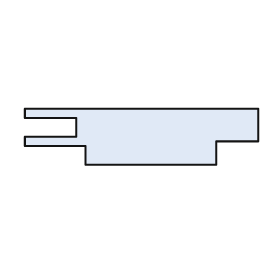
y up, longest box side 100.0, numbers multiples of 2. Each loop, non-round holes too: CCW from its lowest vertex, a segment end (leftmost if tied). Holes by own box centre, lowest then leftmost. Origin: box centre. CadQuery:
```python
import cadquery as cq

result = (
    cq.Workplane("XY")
    .moveTo(-24.0, -12.0)
    .lineTo(32.0, -12.0)
    .lineTo(32.0, -2.0)
    .lineTo(50.0, -2.0)
    .lineTo(50.0, 12.0)
    .lineTo(-50.0, 12.0)
    .lineTo(-50.0, 8.0)
    .lineTo(-28.0, 8.0)
    .lineTo(-28.0, 0.0)
    .lineTo(-50.0, 0.0)
    .lineTo(-50.0, -4.0)
    .lineTo(-24.0, -4.0)
    .close()
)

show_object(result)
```